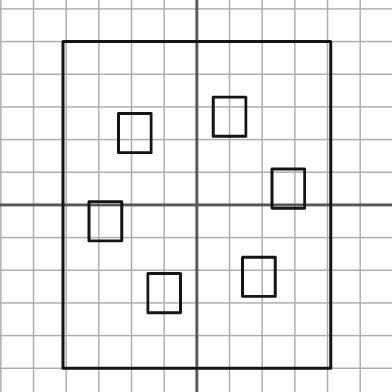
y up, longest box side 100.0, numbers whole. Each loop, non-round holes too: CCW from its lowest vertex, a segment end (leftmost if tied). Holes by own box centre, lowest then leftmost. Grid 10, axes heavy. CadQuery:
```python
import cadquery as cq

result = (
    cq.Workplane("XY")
    .moveTo(-41.0, -50.0)
    .lineTo(41.0, -50.0)
    .lineTo(41.0, 50.0)
    .lineTo(-41.0, 50.0)
    .close()
    .moveTo(-15.0, -33.0)
    .lineTo(-5.0, -33.0)
    .lineTo(-5.0, -21.0)
    .lineTo(-15.0, -21.0)
    .close()
    .moveTo(14.0, -28.0)
    .lineTo(24.0, -28.0)
    .lineTo(24.0, -16.0)
    .lineTo(14.0, -16.0)
    .close()
    .moveTo(-33.0, -11.0)
    .lineTo(-23.0, -11.0)
    .lineTo(-23.0, 1.0)
    .lineTo(-33.0, 1.0)
    .close()
    .moveTo(23.0, -1.0)
    .lineTo(33.0, -1.0)
    .lineTo(33.0, 11.0)
    .lineTo(23.0, 11.0)
    .close()
    .moveTo(-24.0, 16.0)
    .lineTo(-14.0, 16.0)
    .lineTo(-14.0, 28.0)
    .lineTo(-24.0, 28.0)
    .close()
    .moveTo(5.0, 21.0)
    .lineTo(15.0, 21.0)
    .lineTo(15.0, 33.0)
    .lineTo(5.0, 33.0)
    .close()
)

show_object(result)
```